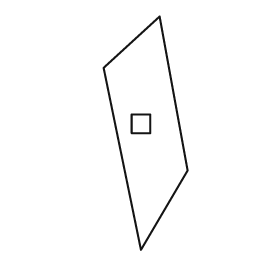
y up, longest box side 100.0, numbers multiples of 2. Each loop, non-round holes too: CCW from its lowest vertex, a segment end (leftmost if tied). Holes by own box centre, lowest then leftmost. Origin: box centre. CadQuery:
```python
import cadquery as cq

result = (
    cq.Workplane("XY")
    .moveTo(-2.0, -50.0)
    .lineTo(18.0, -16.0)
    .lineTo(6.0, 50.0)
    .lineTo(-18.0, 28.0)
    .close()
    .moveTo(-6.0, 0.0)
    .lineTo(2.0, 0.0)
    .lineTo(2.0, 8.0)
    .lineTo(-6.0, 8.0)
    .close()
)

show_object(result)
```